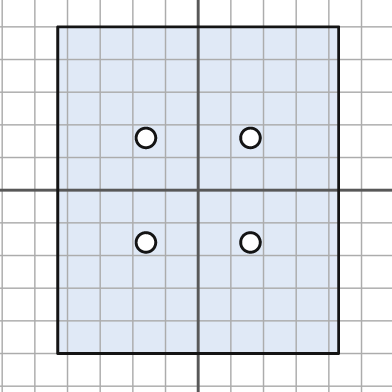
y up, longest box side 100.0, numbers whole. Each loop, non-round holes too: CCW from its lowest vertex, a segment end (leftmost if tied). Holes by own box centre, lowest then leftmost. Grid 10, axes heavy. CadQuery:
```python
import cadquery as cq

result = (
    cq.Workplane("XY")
    .moveTo(-43.0, -50.0)
    .lineTo(43.0, -50.0)
    .lineTo(43.0, 50.0)
    .lineTo(-43.0, 50.0)
    .close()
    .moveTo(-16.0, -16.0)
    .circle(3.0)
    .moveTo(16.0, -16.0)
    .circle(3.0)
    .moveTo(-16.0, 16.0)
    .circle(3.0)
    .moveTo(16.0, 16.0)
    .circle(3.0)
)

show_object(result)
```